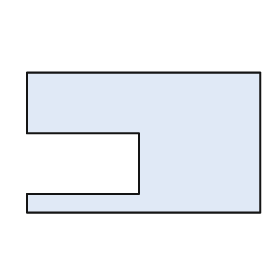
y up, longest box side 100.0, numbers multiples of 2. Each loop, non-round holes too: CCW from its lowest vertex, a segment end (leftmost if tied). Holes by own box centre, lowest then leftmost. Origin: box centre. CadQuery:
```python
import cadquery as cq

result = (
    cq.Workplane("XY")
    .moveTo(-50.0, -30.0)
    .lineTo(50.0, -30.0)
    .lineTo(50.0, 30.0)
    .lineTo(-50.0, 30.0)
    .lineTo(-50.0, 4.0)
    .lineTo(-2.0, 4.0)
    .lineTo(-2.0, -22.0)
    .lineTo(-50.0, -22.0)
    .close()
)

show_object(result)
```